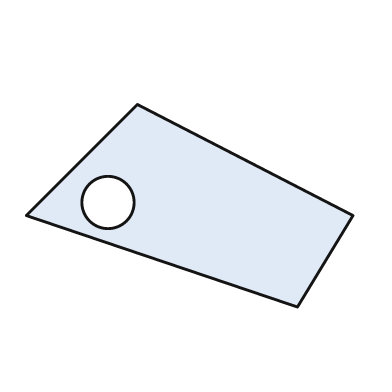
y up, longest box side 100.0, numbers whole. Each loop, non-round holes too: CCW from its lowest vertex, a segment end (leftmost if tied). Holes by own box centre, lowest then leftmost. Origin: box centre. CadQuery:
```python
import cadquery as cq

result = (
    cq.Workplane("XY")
    .moveTo(33.0, -31.0)
    .lineTo(50.0, -3.0)
    .lineTo(-16.0, 31.0)
    .lineTo(-50.0, -3.0)
    .close()
    .moveTo(-25.0, 1.0)
    .circle(8.0)
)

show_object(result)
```